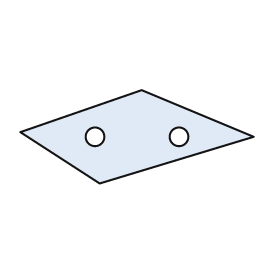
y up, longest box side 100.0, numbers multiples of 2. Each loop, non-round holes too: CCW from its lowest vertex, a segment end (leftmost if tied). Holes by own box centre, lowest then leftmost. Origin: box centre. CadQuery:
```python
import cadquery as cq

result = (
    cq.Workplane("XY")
    .moveTo(-16.0, -20.0)
    .lineTo(50.0, 0.0)
    .lineTo(2.0, 20.0)
    .lineTo(-50.0, 2.0)
    .close()
    .moveTo(-18.0, 0.0)
    .circle(4.0)
    .moveTo(18.0, 0.0)
    .circle(4.0)
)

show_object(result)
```